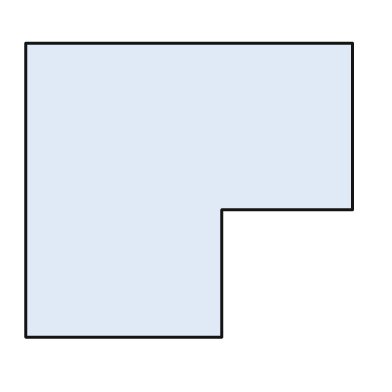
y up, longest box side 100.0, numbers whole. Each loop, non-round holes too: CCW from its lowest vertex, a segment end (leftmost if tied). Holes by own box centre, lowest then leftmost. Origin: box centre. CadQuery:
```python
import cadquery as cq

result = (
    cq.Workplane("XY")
    .moveTo(-50.0, -45.0)
    .lineTo(10.0, -45.0)
    .lineTo(10.0, -6.0)
    .lineTo(50.0, -6.0)
    .lineTo(50.0, 45.0)
    .lineTo(-50.0, 45.0)
    .close()
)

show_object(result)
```